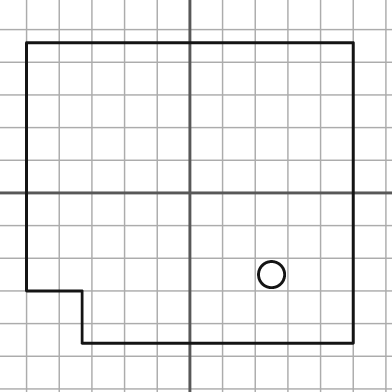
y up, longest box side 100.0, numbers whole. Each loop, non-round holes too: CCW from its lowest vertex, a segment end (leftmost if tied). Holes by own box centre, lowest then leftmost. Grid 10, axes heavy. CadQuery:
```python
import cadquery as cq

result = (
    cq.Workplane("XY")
    .moveTo(-33.0, -46.0)
    .lineTo(50.0, -46.0)
    .lineTo(50.0, 46.0)
    .lineTo(-50.0, 46.0)
    .lineTo(-50.0, -30.0)
    .lineTo(-33.0, -30.0)
    .close()
    .moveTo(25.0, -25.0)
    .circle(4.0)
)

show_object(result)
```